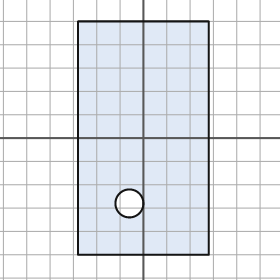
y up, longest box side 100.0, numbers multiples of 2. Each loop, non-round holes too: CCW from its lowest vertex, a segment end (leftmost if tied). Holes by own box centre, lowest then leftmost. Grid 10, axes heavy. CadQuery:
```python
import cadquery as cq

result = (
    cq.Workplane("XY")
    .moveTo(-28.0, -50.0)
    .lineTo(28.0, -50.0)
    .lineTo(28.0, 50.0)
    .lineTo(-28.0, 50.0)
    .close()
    .moveTo(-6.0, -28.0)
    .circle(6.0)
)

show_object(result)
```